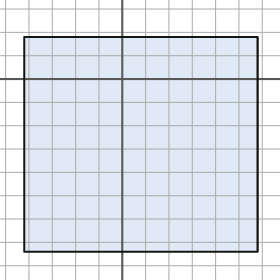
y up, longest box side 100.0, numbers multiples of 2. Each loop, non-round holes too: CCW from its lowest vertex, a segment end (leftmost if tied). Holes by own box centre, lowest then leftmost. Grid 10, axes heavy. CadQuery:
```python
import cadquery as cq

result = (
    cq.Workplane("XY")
    .moveTo(-42.0, -74.0)
    .lineTo(58.0, -74.0)
    .lineTo(58.0, 18.0)
    .lineTo(-42.0, 18.0)
    .close()
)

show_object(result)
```